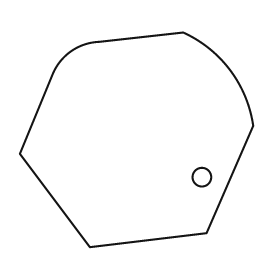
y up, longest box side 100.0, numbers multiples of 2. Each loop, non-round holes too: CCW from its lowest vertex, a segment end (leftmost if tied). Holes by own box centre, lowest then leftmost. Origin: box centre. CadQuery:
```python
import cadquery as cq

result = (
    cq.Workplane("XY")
    .moveTo(-20.0, -46.0)
    .lineTo(30.0, -40.0)
    .lineTo(50.0, 6.0)
    .threePointArc((40.0, 30.0), (20.0, 46.0))
    .lineTo(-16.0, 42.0)
    .threePointArc((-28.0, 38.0), (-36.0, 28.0))
    .lineTo(-50.0, -6.0)
    .close()
    .moveTo(28.0, -16.0)
    .circle(4.0)
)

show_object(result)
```